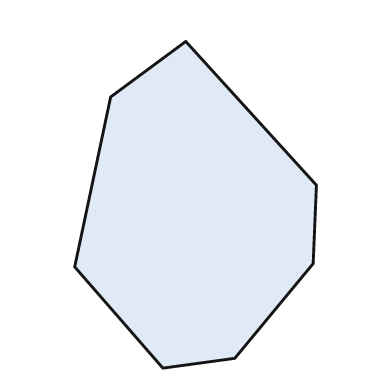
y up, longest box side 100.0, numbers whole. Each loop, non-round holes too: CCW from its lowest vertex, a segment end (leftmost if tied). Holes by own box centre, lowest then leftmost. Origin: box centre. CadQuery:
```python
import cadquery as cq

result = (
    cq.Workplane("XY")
    .moveTo(-10.0, -50.0)
    .lineTo(12.0, -47.0)
    .lineTo(36.0, -18.0)
    .lineTo(37.0, 6.0)
    .lineTo(-3.0, 50.0)
    .lineTo(-26.0, 33.0)
    .lineTo(-37.0, -19.0)
    .close()
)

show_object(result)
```